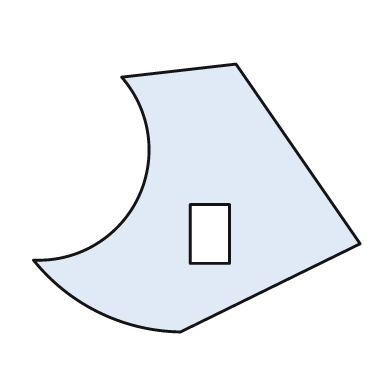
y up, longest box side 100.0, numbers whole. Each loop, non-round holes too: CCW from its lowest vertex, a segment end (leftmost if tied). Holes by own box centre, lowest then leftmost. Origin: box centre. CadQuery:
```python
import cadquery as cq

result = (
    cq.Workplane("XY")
    .moveTo(-5.0, -41.0)
    .lineTo(50.0, -14.0)
    .lineTo(12.0, 41.0)
    .lineTo(-23.0, 37.0)
    .threePointArc((-18.0, 0.0), (-50.0, -19.0))
    .threePointArc((-30.0, -35.0), (-5.0, -41.0))
    .close()
    .moveTo(-2.0, -20.0)
    .lineTo(10.0, -20.0)
    .lineTo(10.0, -2.0)
    .lineTo(-2.0, -2.0)
    .close()
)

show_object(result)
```